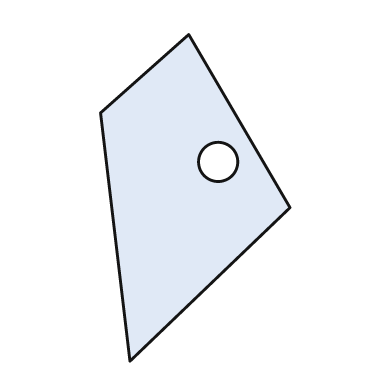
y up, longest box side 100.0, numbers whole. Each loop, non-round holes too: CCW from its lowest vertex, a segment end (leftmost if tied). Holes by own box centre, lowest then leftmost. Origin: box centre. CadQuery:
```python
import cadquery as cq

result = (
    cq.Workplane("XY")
    .moveTo(-20.0, -50.0)
    .lineTo(29.0, -3.0)
    .lineTo(-2.0, 50.0)
    .lineTo(-29.0, 26.0)
    .close()
    .moveTo(7.0, 11.0)
    .circle(6.0)
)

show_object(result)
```